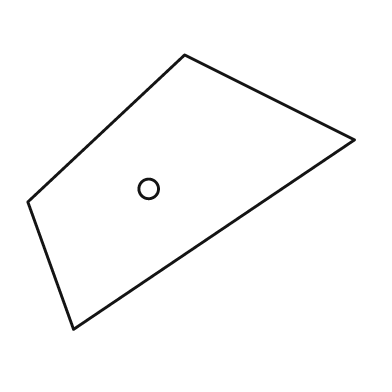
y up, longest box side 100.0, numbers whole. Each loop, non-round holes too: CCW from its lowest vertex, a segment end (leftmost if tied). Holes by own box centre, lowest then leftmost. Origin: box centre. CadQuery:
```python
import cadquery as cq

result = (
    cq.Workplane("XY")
    .moveTo(-36.0, -42.0)
    .lineTo(50.0, 16.0)
    .lineTo(-2.0, 42.0)
    .lineTo(-50.0, -3.0)
    .close()
    .moveTo(-13.0, 1.0)
    .circle(3.0)
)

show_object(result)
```